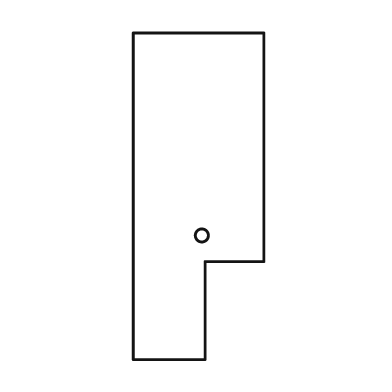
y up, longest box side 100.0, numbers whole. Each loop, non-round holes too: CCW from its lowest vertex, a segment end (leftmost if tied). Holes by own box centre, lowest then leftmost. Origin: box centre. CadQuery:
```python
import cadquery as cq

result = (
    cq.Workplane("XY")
    .moveTo(-20.0, -50.0)
    .lineTo(2.0, -50.0)
    .lineTo(2.0, -20.0)
    .lineTo(20.0, -20.0)
    .lineTo(20.0, 50.0)
    .lineTo(-20.0, 50.0)
    .close()
    .moveTo(1.0, -12.0)
    .circle(2.0)
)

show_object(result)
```